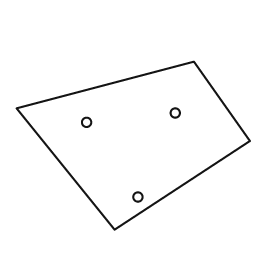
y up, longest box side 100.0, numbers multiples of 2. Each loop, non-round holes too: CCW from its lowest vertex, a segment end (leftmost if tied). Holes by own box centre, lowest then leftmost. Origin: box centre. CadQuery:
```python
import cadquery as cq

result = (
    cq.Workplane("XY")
    .moveTo(-8.0, -36.0)
    .lineTo(50.0, 2.0)
    .lineTo(26.0, 36.0)
    .lineTo(-50.0, 16.0)
    .close()
    .moveTo(2.0, -22.0)
    .circle(2.0)
    .moveTo(-20.0, 10.0)
    .circle(2.0)
    .moveTo(18.0, 14.0)
    .circle(2.0)
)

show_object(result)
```